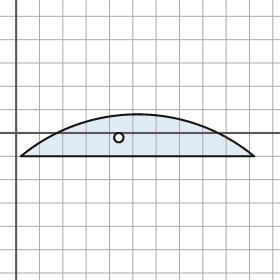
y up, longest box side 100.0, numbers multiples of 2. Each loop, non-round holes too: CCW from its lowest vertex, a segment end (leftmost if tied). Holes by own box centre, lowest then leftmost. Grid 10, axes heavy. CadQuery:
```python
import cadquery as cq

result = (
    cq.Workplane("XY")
    .moveTo(2.0, -10.0)
    .lineTo(102.0, -10.0)
    .threePointArc((52.0, 8.0), (2.0, -10.0))
    .close()
    .moveTo(44.0, -2.0)
    .circle(2.0)
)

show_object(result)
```